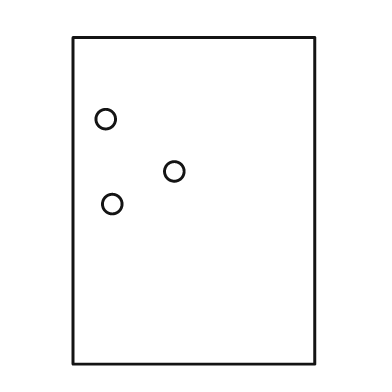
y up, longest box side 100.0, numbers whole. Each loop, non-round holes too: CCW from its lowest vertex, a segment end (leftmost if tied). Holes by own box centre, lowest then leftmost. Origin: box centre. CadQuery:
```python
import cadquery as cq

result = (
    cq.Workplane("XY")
    .moveTo(-37.0, -50.0)
    .lineTo(37.0, -50.0)
    .lineTo(37.0, 50.0)
    .lineTo(-37.0, 50.0)
    .close()
    .moveTo(-25.0, -1.0)
    .circle(3.0)
    .moveTo(-6.0, 9.0)
    .circle(3.0)
    .moveTo(-27.0, 25.0)
    .circle(3.0)
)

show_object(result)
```